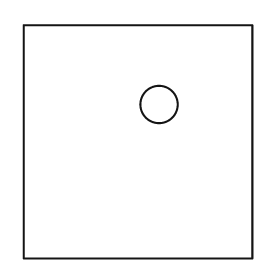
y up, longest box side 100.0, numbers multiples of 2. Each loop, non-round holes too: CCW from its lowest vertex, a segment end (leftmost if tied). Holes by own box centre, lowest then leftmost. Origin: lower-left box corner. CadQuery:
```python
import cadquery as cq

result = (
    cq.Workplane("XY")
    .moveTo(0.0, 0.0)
    .lineTo(98.0, 0.0)
    .lineTo(98.0, 100.0)
    .lineTo(0.0, 100.0)
    .close()
    .moveTo(58.0, 66.0)
    .circle(8.0)
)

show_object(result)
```